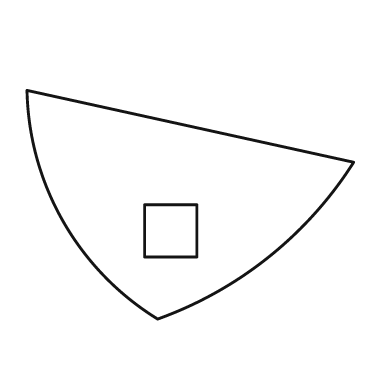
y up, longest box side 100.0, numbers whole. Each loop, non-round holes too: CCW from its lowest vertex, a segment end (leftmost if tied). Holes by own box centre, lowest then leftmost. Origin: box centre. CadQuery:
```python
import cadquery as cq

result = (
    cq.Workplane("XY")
    .moveTo(-10.0, -35.0)
    .threePointArc((24.0, -16.0), (50.0, 13.0))
    .lineTo(-50.0, 35.0)
    .threePointArc((-39.0, -5.0), (-10.0, -35.0))
    .close()
    .moveTo(-14.0, -16.0)
    .lineTo(2.0, -16.0)
    .lineTo(2.0, 0.0)
    .lineTo(-14.0, 0.0)
    .close()
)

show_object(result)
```